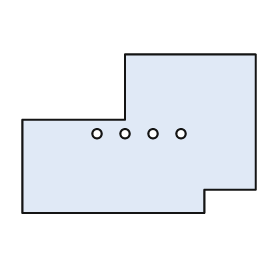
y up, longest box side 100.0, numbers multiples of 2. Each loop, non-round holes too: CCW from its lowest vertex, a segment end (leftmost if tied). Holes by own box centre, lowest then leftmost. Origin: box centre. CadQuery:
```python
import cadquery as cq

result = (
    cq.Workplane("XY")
    .moveTo(-50.0, -34.0)
    .lineTo(28.0, -34.0)
    .lineTo(28.0, -24.0)
    .lineTo(50.0, -24.0)
    .lineTo(50.0, 34.0)
    .lineTo(-6.0, 34.0)
    .lineTo(-6.0, 6.0)
    .lineTo(-50.0, 6.0)
    .close()
    .moveTo(-18.0, 0.0)
    .circle(2.0)
    .moveTo(-6.0, 0.0)
    .circle(2.0)
    .moveTo(6.0, 0.0)
    .circle(2.0)
    .moveTo(18.0, 0.0)
    .circle(2.0)
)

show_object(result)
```